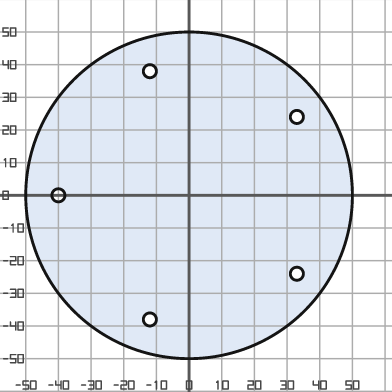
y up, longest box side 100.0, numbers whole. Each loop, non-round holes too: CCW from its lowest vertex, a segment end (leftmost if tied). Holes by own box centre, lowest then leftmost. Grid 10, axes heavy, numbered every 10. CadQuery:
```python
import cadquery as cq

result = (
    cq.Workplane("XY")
    .moveTo(0.0, 0.0)
    .circle(50.0)
    .moveTo(-12.0, -38.0)
    .circle(2.0)
    .moveTo(33.0, -24.0)
    .circle(2.0)
    .moveTo(-40.0, 0.0)
    .circle(2.0)
    .moveTo(33.0, 24.0)
    .circle(2.0)
    .moveTo(-12.0, 38.0)
    .circle(2.0)
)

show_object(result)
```